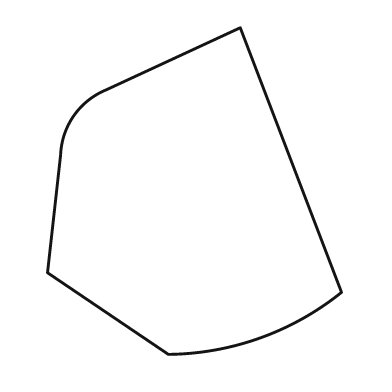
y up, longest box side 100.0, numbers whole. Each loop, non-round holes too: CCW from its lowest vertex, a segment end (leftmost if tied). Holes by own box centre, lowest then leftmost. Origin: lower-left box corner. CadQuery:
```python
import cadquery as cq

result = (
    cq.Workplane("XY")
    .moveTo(37.0, 0.0)
    .threePointArc((65.0, 5.0), (90.0, 19.0))
    .lineTo(59.0, 100.0)
    .lineTo(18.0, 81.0)
    .threePointArc((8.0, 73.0), (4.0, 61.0))
    .lineTo(0.0, 25.0)
    .close()
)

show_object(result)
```